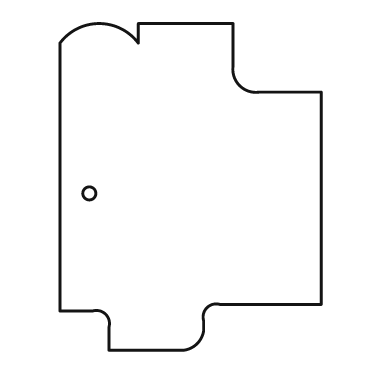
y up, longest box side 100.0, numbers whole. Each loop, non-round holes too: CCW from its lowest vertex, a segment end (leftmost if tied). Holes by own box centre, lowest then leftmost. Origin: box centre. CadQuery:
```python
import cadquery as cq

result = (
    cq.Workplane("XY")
    .moveTo(-25.0, -50.0)
    .lineTo(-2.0, -50.0)
    .threePointArc((2.0, -48.0), (4.0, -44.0))
    .lineTo(4.0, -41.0)
    .threePointArc((5.0, -37.0), (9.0, -36.0))
    .lineTo(40.0, -36.0)
    .lineTo(40.0, 29.0)
    .lineTo(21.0, 29.0)
    .threePointArc((15.0, 31.0), (13.0, 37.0))
    .lineTo(13.0, 50.0)
    .lineTo(-16.0, 50.0)
    .lineTo(-16.0, 44.0)
    .threePointArc((-28.0, 50.0), (-40.0, 44.0))
    .lineTo(-40.0, -38.0)
    .lineTo(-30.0, -38.0)
    .threePointArc((-26.0, -39.0), (-25.0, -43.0))
    .close()
    .moveTo(-31.0, -2.0)
    .circle(2.0)
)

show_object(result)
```